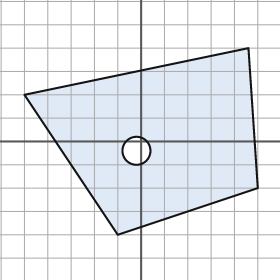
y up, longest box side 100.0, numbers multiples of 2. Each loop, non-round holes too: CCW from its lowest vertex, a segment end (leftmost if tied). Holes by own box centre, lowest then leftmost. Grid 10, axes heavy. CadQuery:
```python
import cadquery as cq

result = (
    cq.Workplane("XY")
    .moveTo(-10.0, -40.0)
    .lineTo(50.0, -20.0)
    .lineTo(46.0, 40.0)
    .lineTo(-50.0, 20.0)
    .close()
    .moveTo(-2.0, -4.0)
    .circle(6.0)
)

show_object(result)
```